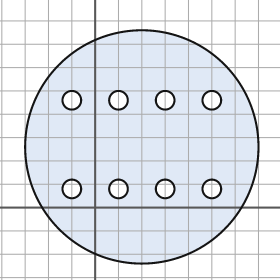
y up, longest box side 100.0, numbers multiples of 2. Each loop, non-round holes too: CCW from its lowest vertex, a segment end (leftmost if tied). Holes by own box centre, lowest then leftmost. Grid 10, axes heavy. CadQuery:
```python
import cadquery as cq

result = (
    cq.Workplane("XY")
    .moveTo(20.0, 26.0)
    .circle(50.0)
    .moveTo(-10.0, 8.0)
    .circle(4.0)
    .moveTo(10.0, 8.0)
    .circle(4.0)
    .moveTo(30.0, 8.0)
    .circle(4.0)
    .moveTo(50.0, 8.0)
    .circle(4.0)
    .moveTo(-10.0, 46.0)
    .circle(4.0)
    .moveTo(10.0, 46.0)
    .circle(4.0)
    .moveTo(30.0, 46.0)
    .circle(4.0)
    .moveTo(50.0, 46.0)
    .circle(4.0)
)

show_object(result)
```